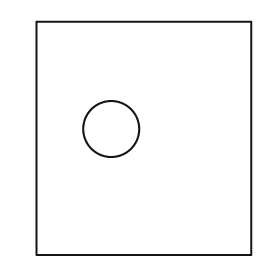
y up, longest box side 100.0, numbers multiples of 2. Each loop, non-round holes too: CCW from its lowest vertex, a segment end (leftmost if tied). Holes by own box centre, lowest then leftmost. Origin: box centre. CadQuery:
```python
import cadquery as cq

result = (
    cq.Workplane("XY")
    .moveTo(-46.0, -50.0)
    .lineTo(46.0, -50.0)
    .lineTo(46.0, 50.0)
    .lineTo(-46.0, 50.0)
    .close()
    .moveTo(-14.0, 4.0)
    .circle(12.0)
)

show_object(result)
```